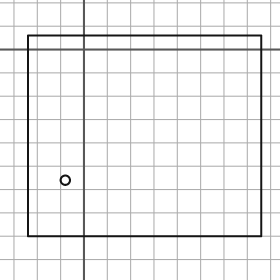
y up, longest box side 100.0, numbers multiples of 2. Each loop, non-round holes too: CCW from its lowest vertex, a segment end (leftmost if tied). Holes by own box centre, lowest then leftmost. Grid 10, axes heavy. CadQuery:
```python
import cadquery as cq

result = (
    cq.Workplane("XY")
    .moveTo(-24.0, -80.0)
    .lineTo(76.0, -80.0)
    .lineTo(76.0, 6.0)
    .lineTo(-24.0, 6.0)
    .close()
    .moveTo(-8.0, -56.0)
    .circle(2.0)
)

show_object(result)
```